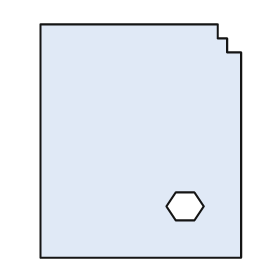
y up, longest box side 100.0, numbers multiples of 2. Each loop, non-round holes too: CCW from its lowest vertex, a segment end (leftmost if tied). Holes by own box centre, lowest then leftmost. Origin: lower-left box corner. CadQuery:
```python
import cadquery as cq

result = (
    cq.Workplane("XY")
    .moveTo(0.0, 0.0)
    .lineTo(86.0, 0.0)
    .lineTo(86.0, 88.0)
    .lineTo(80.0, 88.0)
    .lineTo(80.0, 94.0)
    .lineTo(76.0, 94.0)
    .lineTo(76.0, 100.0)
    .lineTo(0.0, 100.0)
    .close()
    .moveTo(58.0, 16.0)
    .lineTo(66.0, 16.0)
    .lineTo(70.0, 22.0)
    .lineTo(66.0, 28.0)
    .lineTo(58.0, 28.0)
    .lineTo(54.0, 22.0)
    .close()
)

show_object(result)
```